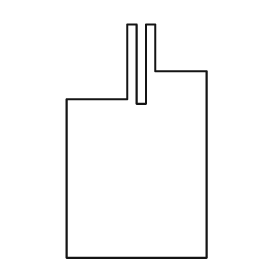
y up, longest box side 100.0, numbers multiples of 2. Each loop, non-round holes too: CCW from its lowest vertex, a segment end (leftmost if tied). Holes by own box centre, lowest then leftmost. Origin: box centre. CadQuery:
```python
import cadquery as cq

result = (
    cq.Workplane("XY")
    .moveTo(-30.0, -50.0)
    .lineTo(30.0, -50.0)
    .lineTo(30.0, 30.0)
    .lineTo(8.0, 30.0)
    .lineTo(8.0, 50.0)
    .lineTo(4.0, 50.0)
    .lineTo(4.0, 16.0)
    .lineTo(0.0, 16.0)
    .lineTo(0.0, 50.0)
    .lineTo(-4.0, 50.0)
    .lineTo(-4.0, 18.0)
    .lineTo(-30.0, 18.0)
    .close()
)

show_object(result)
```